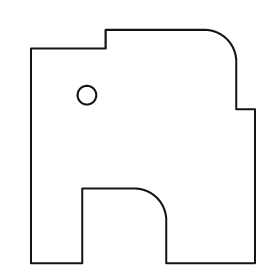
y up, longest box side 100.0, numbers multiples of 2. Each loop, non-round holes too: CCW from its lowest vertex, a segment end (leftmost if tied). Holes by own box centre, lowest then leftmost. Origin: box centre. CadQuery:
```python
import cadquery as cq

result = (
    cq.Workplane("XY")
    .moveTo(-48.0, -50.0)
    .lineTo(-26.0, -50.0)
    .lineTo(-26.0, -18.0)
    .lineTo(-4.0, -18.0)
    .threePointArc((6.0, -22.0), (10.0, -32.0))
    .lineTo(10.0, -50.0)
    .lineTo(48.0, -50.0)
    .lineTo(48.0, 16.0)
    .lineTo(40.0, 16.0)
    .lineTo(40.0, 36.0)
    .threePointArc((36.0, 46.0), (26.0, 50.0))
    .lineTo(-16.0, 50.0)
    .lineTo(-16.0, 42.0)
    .lineTo(-48.0, 42.0)
    .close()
    .moveTo(-24.0, 22.0)
    .circle(4.0)
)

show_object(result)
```